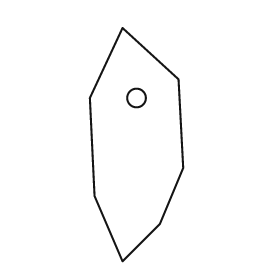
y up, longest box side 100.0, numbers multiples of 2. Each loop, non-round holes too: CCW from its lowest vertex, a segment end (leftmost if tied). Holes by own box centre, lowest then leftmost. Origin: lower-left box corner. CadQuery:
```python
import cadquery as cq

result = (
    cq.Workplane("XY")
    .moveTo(14.0, 0.0)
    .lineTo(30.0, 16.0)
    .lineTo(40.0, 40.0)
    .lineTo(38.0, 78.0)
    .lineTo(14.0, 100.0)
    .lineTo(0.0, 70.0)
    .lineTo(2.0, 28.0)
    .close()
    .moveTo(20.0, 70.0)
    .circle(4.0)
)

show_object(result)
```